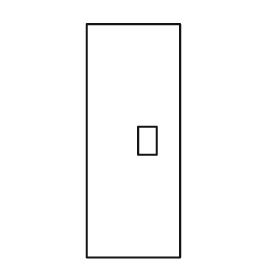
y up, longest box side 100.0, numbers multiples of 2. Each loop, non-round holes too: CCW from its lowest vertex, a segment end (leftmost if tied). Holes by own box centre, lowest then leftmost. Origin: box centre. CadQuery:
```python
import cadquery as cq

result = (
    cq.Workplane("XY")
    .moveTo(-20.0, -50.0)
    .lineTo(20.0, -50.0)
    .lineTo(20.0, 50.0)
    .lineTo(-20.0, 50.0)
    .close()
    .moveTo(2.0, -6.0)
    .lineTo(10.0, -6.0)
    .lineTo(10.0, 6.0)
    .lineTo(2.0, 6.0)
    .close()
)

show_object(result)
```